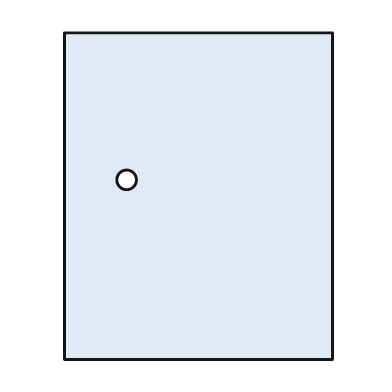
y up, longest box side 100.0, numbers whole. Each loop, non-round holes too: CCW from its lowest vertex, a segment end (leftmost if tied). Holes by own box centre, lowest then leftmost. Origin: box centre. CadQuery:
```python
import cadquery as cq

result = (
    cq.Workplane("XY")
    .moveTo(-41.0, -50.0)
    .lineTo(41.0, -50.0)
    .lineTo(41.0, 50.0)
    .lineTo(-41.0, 50.0)
    .close()
    .moveTo(-22.0, 5.0)
    .circle(3.0)
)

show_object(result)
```